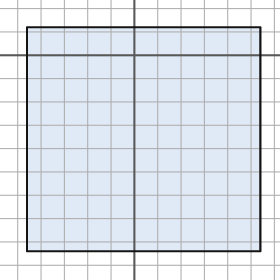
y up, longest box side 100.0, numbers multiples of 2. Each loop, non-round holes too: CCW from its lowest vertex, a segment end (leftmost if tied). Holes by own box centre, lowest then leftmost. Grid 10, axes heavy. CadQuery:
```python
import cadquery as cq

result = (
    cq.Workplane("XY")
    .moveTo(-46.0, -84.0)
    .lineTo(54.0, -84.0)
    .lineTo(54.0, 12.0)
    .lineTo(-46.0, 12.0)
    .close()
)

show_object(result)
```